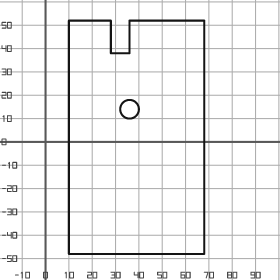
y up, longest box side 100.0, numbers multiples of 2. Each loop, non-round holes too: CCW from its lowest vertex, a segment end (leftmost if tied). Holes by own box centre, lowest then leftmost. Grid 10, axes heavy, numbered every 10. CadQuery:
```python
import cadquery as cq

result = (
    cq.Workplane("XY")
    .moveTo(10.0, -48.0)
    .lineTo(68.0, -48.0)
    .lineTo(68.0, 52.0)
    .lineTo(36.0, 52.0)
    .lineTo(36.0, 38.0)
    .lineTo(28.0, 38.0)
    .lineTo(28.0, 52.0)
    .lineTo(10.0, 52.0)
    .close()
    .moveTo(36.0, 14.0)
    .circle(4.0)
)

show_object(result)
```